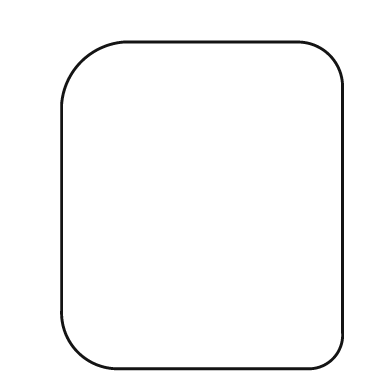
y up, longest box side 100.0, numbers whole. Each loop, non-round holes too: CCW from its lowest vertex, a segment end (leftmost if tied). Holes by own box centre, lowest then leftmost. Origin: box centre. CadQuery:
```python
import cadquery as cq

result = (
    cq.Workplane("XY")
    .moveTo(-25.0, -50.0)
    .lineTo(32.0, -50.0)
    .threePointArc((40.0, -47.0), (43.0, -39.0))
    .lineTo(43.0, 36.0)
    .threePointArc((39.0, 46.0), (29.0, 50.0))
    .lineTo(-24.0, 50.0)
    .threePointArc((-37.0, 44.0), (-43.0, 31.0))
    .lineTo(-43.0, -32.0)
    .threePointArc((-38.0, -45.0), (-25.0, -50.0))
    .close()
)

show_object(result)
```